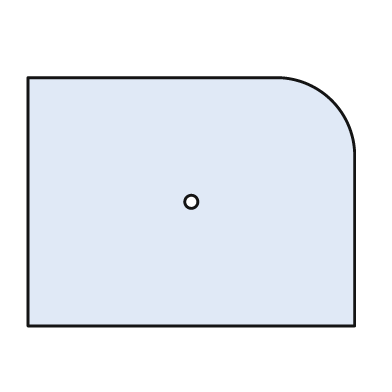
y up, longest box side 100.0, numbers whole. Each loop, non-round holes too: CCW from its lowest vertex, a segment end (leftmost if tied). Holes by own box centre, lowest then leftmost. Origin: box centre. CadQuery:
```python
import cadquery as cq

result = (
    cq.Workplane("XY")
    .moveTo(-50.0, -38.0)
    .lineTo(50.0, -38.0)
    .lineTo(50.0, 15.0)
    .threePointArc((43.0, 31.0), (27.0, 38.0))
    .lineTo(-50.0, 38.0)
    .close()
    .moveTo(0.0, 0.0)
    .circle(2.0)
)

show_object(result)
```